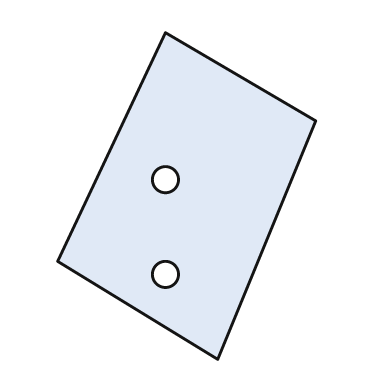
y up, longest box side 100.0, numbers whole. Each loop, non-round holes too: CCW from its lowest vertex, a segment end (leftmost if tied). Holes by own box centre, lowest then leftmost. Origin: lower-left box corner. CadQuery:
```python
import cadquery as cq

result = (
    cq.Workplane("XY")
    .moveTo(49.0, 0.0)
    .lineTo(79.0, 73.0)
    .lineTo(33.0, 100.0)
    .lineTo(0.0, 30.0)
    .close()
    .moveTo(33.0, 26.0)
    .circle(4.0)
    .moveTo(33.0, 55.0)
    .circle(4.0)
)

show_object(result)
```